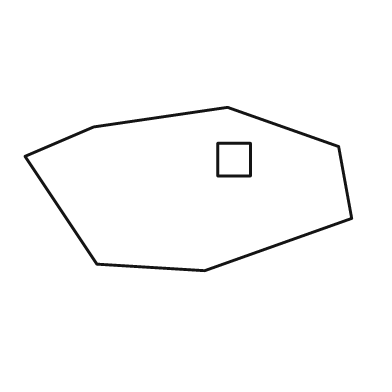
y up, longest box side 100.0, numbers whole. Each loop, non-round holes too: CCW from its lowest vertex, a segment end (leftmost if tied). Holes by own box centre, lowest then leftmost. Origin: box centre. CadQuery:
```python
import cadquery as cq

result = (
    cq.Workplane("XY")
    .moveTo(5.0, -25.0)
    .lineTo(50.0, -9.0)
    .lineTo(46.0, 13.0)
    .lineTo(12.0, 25.0)
    .lineTo(-29.0, 19.0)
    .lineTo(-50.0, 10.0)
    .lineTo(-28.0, -23.0)
    .close()
    .moveTo(9.0, 4.0)
    .lineTo(19.0, 4.0)
    .lineTo(19.0, 14.0)
    .lineTo(9.0, 14.0)
    .close()
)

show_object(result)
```